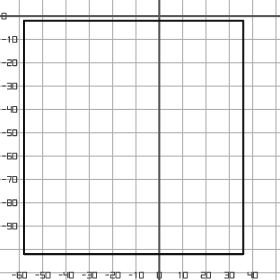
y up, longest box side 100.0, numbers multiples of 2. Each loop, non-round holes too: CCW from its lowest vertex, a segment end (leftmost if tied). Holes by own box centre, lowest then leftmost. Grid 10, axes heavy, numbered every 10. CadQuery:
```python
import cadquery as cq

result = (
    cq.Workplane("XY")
    .moveTo(-58.0, -102.0)
    .lineTo(36.0, -102.0)
    .lineTo(36.0, -2.0)
    .lineTo(-58.0, -2.0)
    .close()
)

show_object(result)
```